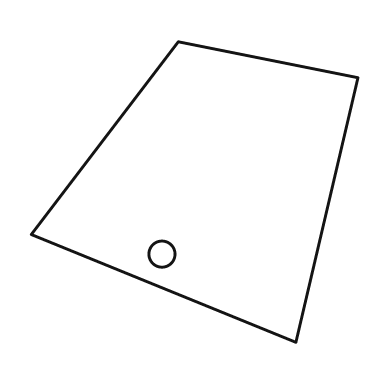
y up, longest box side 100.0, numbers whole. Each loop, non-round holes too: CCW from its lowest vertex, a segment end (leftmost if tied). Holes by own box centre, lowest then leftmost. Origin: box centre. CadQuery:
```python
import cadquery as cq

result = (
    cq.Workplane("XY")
    .moveTo(31.0, -46.0)
    .lineTo(50.0, 35.0)
    .lineTo(-5.0, 46.0)
    .lineTo(-50.0, -13.0)
    .close()
    .moveTo(-10.0, -19.0)
    .circle(4.0)
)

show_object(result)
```